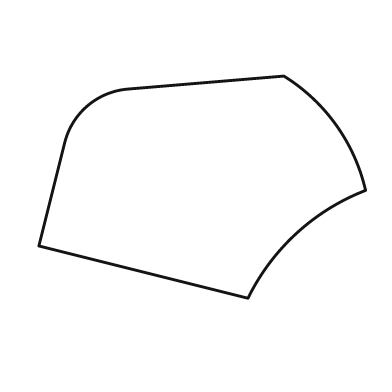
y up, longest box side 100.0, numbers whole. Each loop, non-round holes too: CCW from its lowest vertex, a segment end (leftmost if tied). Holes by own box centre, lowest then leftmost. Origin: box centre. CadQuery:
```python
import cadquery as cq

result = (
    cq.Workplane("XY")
    .moveTo(14.0, -34.0)
    .threePointArc((29.0, -14.0), (50.0, -1.0))
    .threePointArc((41.0, 19.0), (25.0, 34.0))
    .lineTo(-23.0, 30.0)
    .threePointArc((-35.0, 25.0), (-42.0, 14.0))
    .lineTo(-50.0, -18.0)
    .close()
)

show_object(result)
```